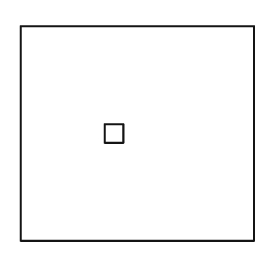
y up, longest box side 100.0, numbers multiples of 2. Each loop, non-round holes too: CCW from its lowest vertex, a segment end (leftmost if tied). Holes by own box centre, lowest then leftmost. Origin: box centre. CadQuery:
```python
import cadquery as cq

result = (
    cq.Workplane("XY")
    .moveTo(-50.0, -46.0)
    .lineTo(50.0, -46.0)
    .lineTo(50.0, 46.0)
    .lineTo(-50.0, 46.0)
    .close()
    .moveTo(-14.0, -4.0)
    .lineTo(-6.0, -4.0)
    .lineTo(-6.0, 4.0)
    .lineTo(-14.0, 4.0)
    .close()
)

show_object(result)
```